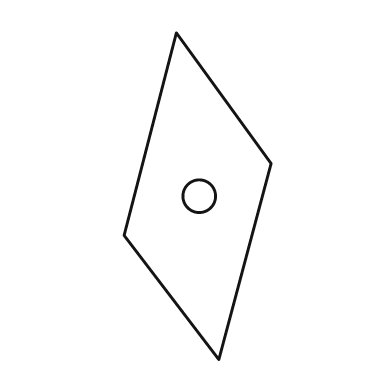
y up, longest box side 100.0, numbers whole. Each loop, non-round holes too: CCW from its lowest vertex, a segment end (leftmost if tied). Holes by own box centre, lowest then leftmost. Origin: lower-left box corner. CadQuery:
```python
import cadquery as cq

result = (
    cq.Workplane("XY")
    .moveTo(29.0, 0.0)
    .lineTo(45.0, 60.0)
    .lineTo(16.0, 100.0)
    .lineTo(0.0, 38.0)
    .close()
    .moveTo(23.0, 50.0)
    .circle(5.0)
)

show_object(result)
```